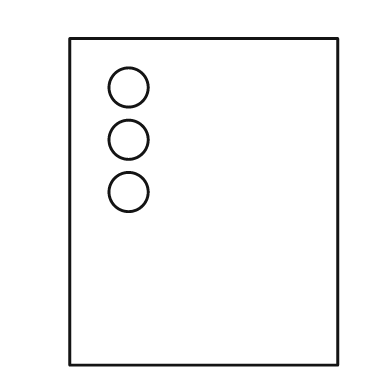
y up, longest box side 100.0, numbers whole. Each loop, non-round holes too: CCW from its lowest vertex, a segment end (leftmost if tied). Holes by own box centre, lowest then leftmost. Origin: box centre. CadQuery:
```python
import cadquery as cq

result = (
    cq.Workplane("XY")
    .moveTo(-41.0, -50.0)
    .lineTo(41.0, -50.0)
    .lineTo(41.0, 50.0)
    .lineTo(-41.0, 50.0)
    .close()
    .moveTo(-23.0, 3.0)
    .circle(6.0)
    .moveTo(-23.0, 19.0)
    .circle(6.0)
    .moveTo(-23.0, 35.0)
    .circle(6.0)
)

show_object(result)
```